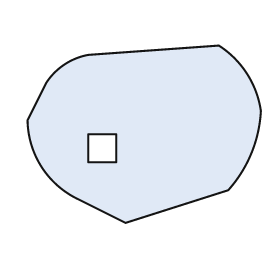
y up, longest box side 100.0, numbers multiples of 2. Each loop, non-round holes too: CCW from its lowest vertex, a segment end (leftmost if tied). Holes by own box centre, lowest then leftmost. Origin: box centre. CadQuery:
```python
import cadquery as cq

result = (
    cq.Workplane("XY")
    .moveTo(-8.0, -38.0)
    .lineTo(36.0, -24.0)
    .threePointArc((46.0, -8.0), (50.0, 10.0))
    .threePointArc((44.0, 26.0), (32.0, 38.0))
    .lineTo(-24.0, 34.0)
    .threePointArc((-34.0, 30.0), (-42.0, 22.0))
    .lineTo(-50.0, 6.0)
    .threePointArc((-44.0, -14.0), (-28.0, -28.0))
    .close()
    .moveTo(-24.0, -12.0)
    .lineTo(-12.0, -12.0)
    .lineTo(-12.0, 0.0)
    .lineTo(-24.0, 0.0)
    .close()
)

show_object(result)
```